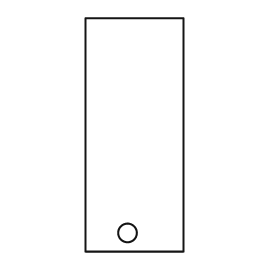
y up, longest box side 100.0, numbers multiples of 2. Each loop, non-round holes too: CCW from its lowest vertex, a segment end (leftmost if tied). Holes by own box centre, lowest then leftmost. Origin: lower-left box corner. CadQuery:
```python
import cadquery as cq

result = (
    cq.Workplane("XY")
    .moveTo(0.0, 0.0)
    .lineTo(42.0, 0.0)
    .lineTo(42.0, 100.0)
    .lineTo(0.0, 100.0)
    .close()
    .moveTo(18.0, 8.0)
    .circle(4.0)
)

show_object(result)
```